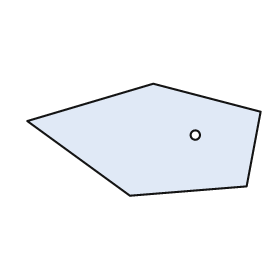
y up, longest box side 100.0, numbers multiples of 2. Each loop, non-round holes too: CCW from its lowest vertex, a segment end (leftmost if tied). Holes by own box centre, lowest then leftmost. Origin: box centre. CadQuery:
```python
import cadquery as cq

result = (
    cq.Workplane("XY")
    .moveTo(-6.0, -24.0)
    .lineTo(44.0, -20.0)
    .lineTo(50.0, 12.0)
    .lineTo(4.0, 24.0)
    .lineTo(-50.0, 8.0)
    .close()
    .moveTo(22.0, 2.0)
    .circle(2.0)
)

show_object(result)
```